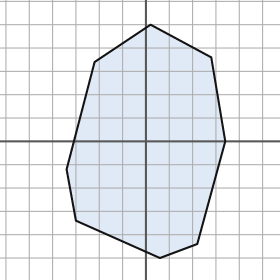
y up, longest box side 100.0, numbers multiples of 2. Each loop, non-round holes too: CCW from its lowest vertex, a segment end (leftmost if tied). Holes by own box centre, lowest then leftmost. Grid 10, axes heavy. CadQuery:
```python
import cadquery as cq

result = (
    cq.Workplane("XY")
    .moveTo(6.0, -50.0)
    .lineTo(22.0, -44.0)
    .lineTo(34.0, 0.0)
    .lineTo(28.0, 36.0)
    .lineTo(2.0, 50.0)
    .lineTo(-22.0, 34.0)
    .lineTo(-34.0, -12.0)
    .lineTo(-30.0, -34.0)
    .close()
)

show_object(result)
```